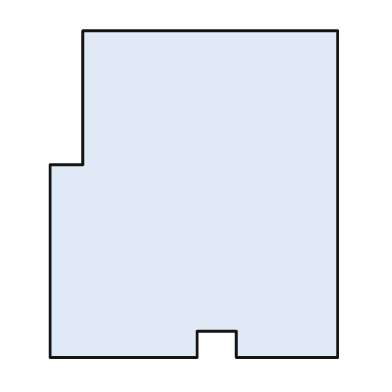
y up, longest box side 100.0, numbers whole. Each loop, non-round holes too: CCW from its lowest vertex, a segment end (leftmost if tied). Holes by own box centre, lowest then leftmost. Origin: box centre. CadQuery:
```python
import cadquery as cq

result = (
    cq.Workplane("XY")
    .moveTo(-44.0, -50.0)
    .lineTo(1.0, -50.0)
    .lineTo(1.0, -42.0)
    .lineTo(13.0, -42.0)
    .lineTo(13.0, -50.0)
    .lineTo(44.0, -50.0)
    .lineTo(44.0, 50.0)
    .lineTo(-34.0, 50.0)
    .lineTo(-34.0, 9.0)
    .lineTo(-44.0, 9.0)
    .close()
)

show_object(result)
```